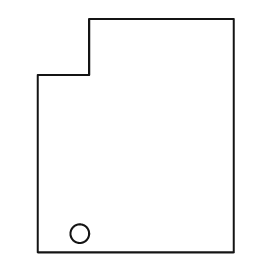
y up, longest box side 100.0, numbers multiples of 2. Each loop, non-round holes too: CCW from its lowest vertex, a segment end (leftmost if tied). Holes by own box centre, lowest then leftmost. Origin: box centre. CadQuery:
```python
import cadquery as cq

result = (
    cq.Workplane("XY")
    .moveTo(-42.0, -50.0)
    .lineTo(42.0, -50.0)
    .lineTo(42.0, 50.0)
    .lineTo(-20.0, 50.0)
    .lineTo(-20.0, 26.0)
    .lineTo(-42.0, 26.0)
    .close()
    .moveTo(-24.0, -42.0)
    .circle(4.0)
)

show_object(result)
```